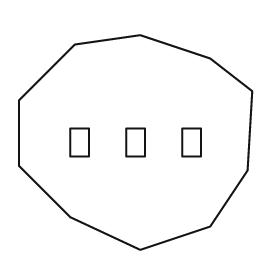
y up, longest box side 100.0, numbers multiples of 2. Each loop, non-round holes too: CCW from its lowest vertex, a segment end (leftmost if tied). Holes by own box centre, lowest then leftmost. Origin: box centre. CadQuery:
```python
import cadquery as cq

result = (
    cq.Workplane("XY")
    .moveTo(2.0, -46.0)
    .lineTo(32.0, -36.0)
    .lineTo(48.0, -12.0)
    .lineTo(50.0, 22.0)
    .lineTo(32.0, 36.0)
    .lineTo(2.0, 46.0)
    .lineTo(-26.0, 42.0)
    .lineTo(-50.0, 18.0)
    .lineTo(-50.0, -10.0)
    .lineTo(-28.0, -32.0)
    .close()
    .moveTo(-28.0, -6.0)
    .lineTo(-20.0, -6.0)
    .lineTo(-20.0, 6.0)
    .lineTo(-28.0, 6.0)
    .close()
    .moveTo(-4.0, -6.0)
    .lineTo(4.0, -6.0)
    .lineTo(4.0, 6.0)
    .lineTo(-4.0, 6.0)
    .close()
    .moveTo(20.0, -6.0)
    .lineTo(28.0, -6.0)
    .lineTo(28.0, 6.0)
    .lineTo(20.0, 6.0)
    .close()
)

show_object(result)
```